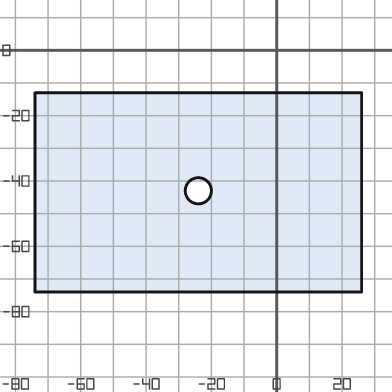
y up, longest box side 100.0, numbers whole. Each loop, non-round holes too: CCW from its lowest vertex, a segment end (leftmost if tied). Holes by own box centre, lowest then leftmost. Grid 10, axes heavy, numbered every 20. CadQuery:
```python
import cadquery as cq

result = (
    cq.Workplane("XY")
    .moveTo(-74.0, -74.0)
    .lineTo(26.0, -74.0)
    .lineTo(26.0, -13.0)
    .lineTo(-74.0, -13.0)
    .close()
    .moveTo(-24.0, -43.0)
    .circle(4.0)
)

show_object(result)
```